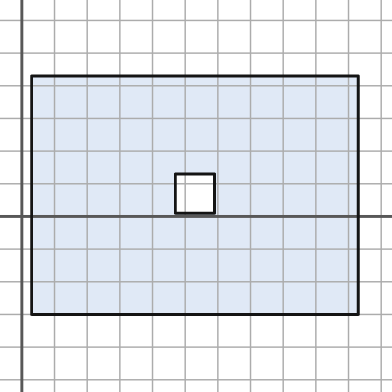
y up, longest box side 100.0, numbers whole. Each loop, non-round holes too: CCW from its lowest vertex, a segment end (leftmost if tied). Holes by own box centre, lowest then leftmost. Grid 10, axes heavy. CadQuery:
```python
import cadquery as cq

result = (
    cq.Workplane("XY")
    .moveTo(3.0, -30.0)
    .lineTo(103.0, -30.0)
    .lineTo(103.0, 43.0)
    .lineTo(3.0, 43.0)
    .close()
    .moveTo(47.0, 1.0)
    .lineTo(59.0, 1.0)
    .lineTo(59.0, 13.0)
    .lineTo(47.0, 13.0)
    .close()
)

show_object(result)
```